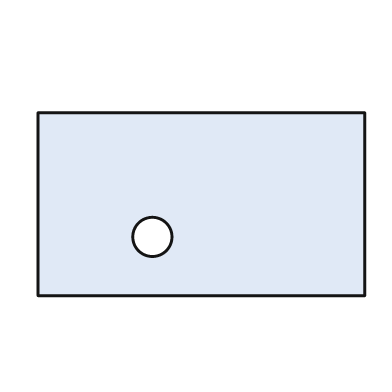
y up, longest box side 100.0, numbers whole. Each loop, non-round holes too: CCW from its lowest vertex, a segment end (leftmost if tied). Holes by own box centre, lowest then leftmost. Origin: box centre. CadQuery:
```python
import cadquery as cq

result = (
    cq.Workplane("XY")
    .moveTo(-50.0, -28.0)
    .lineTo(50.0, -28.0)
    .lineTo(50.0, 28.0)
    .lineTo(-50.0, 28.0)
    .close()
    .moveTo(-15.0, -10.0)
    .circle(6.0)
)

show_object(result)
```